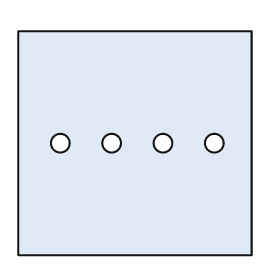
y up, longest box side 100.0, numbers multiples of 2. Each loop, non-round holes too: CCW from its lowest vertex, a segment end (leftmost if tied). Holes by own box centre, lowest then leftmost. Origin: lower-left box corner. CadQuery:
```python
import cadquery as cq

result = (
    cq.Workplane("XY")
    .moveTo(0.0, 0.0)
    .lineTo(100.0, 0.0)
    .lineTo(100.0, 96.0)
    .lineTo(0.0, 96.0)
    .close()
    .moveTo(18.0, 48.0)
    .circle(4.0)
    .moveTo(40.0, 48.0)
    .circle(4.0)
    .moveTo(62.0, 48.0)
    .circle(4.0)
    .moveTo(84.0, 48.0)
    .circle(4.0)
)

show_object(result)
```